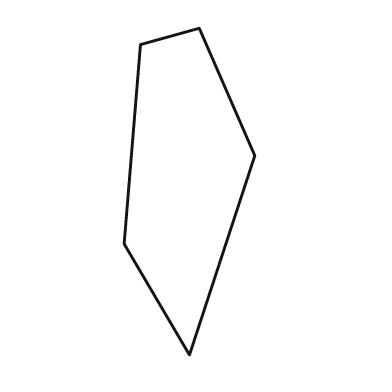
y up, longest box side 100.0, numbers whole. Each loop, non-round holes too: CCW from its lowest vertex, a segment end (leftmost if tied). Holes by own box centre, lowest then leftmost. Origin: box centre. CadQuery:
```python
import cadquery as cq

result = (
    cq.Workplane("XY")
    .moveTo(0.0, -50.0)
    .lineTo(20.0, 11.0)
    .lineTo(3.0, 50.0)
    .lineTo(-15.0, 45.0)
    .lineTo(-20.0, -16.0)
    .close()
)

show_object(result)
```